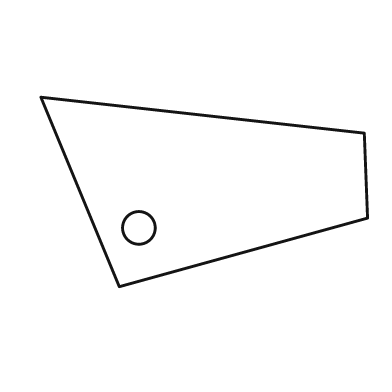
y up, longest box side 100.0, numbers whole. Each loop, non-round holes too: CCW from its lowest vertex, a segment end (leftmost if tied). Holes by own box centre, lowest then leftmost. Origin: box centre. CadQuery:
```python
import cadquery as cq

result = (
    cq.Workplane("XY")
    .moveTo(-26.0, -29.0)
    .lineTo(50.0, -8.0)
    .lineTo(49.0, 18.0)
    .lineTo(-50.0, 29.0)
    .close()
    .moveTo(-20.0, -11.0)
    .circle(5.0)
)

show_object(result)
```